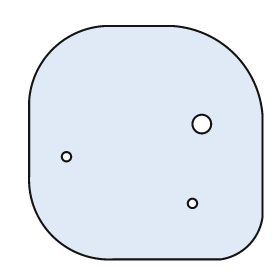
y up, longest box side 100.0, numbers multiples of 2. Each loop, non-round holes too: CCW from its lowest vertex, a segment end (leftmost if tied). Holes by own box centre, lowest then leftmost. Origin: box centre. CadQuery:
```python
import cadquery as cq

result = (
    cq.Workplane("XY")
    .moveTo(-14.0, -50.0)
    .lineTo(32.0, -50.0)
    .threePointArc((44.0, -44.0), (50.0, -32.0))
    .lineTo(50.0, 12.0)
    .threePointArc((38.0, 38.0), (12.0, 50.0))
    .lineTo(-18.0, 50.0)
    .threePointArc((-40.0, 40.0), (-50.0, 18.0))
    .lineTo(-50.0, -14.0)
    .threePointArc((-40.0, -40.0), (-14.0, -50.0))
    .close()
    .moveTo(20.0, -26.0)
    .circle(2.0)
    .moveTo(-34.0, -6.0)
    .circle(2.0)
    .moveTo(24.0, 8.0)
    .circle(4.0)
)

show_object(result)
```